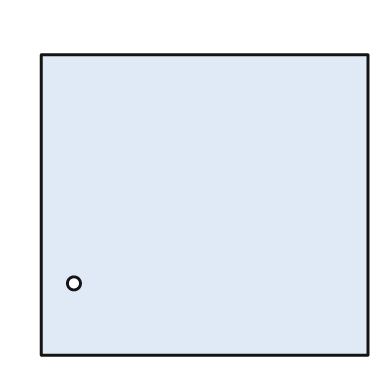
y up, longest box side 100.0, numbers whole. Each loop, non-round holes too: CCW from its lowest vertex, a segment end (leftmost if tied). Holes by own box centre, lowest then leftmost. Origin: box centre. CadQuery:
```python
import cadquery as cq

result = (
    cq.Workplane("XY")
    .moveTo(-50.0, -46.0)
    .lineTo(50.0, -46.0)
    .lineTo(50.0, 46.0)
    .lineTo(-50.0, 46.0)
    .close()
    .moveTo(-40.0, -24.0)
    .circle(2.0)
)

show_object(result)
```